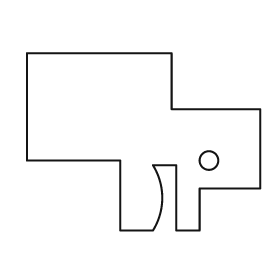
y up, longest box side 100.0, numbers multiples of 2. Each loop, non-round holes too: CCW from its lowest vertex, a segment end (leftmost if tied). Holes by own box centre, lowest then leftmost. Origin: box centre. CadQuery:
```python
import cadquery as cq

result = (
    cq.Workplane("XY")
    .moveTo(-10.0, -38.0)
    .lineTo(4.0, -38.0)
    .threePointArc((8.0, -24.0), (4.0, -10.0))
    .lineTo(14.0, -10.0)
    .lineTo(14.0, -38.0)
    .lineTo(24.0, -38.0)
    .lineTo(24.0, -20.0)
    .lineTo(50.0, -20.0)
    .lineTo(50.0, 14.0)
    .lineTo(12.0, 14.0)
    .lineTo(12.0, 38.0)
    .lineTo(-50.0, 38.0)
    .lineTo(-50.0, -8.0)
    .lineTo(-10.0, -8.0)
    .close()
    .moveTo(28.0, -8.0)
    .circle(4.0)
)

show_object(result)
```